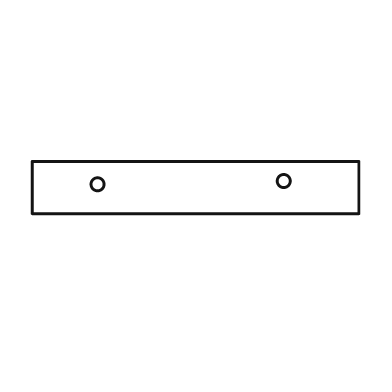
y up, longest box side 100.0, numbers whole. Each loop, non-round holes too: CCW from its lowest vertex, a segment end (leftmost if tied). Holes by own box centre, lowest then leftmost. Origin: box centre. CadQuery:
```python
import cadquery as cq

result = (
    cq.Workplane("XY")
    .moveTo(-50.0, -8.0)
    .lineTo(50.0, -8.0)
    .lineTo(50.0, 8.0)
    .lineTo(-50.0, 8.0)
    .close()
    .moveTo(-30.0, 1.0)
    .circle(2.0)
    .moveTo(27.0, 2.0)
    .circle(2.0)
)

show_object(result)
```